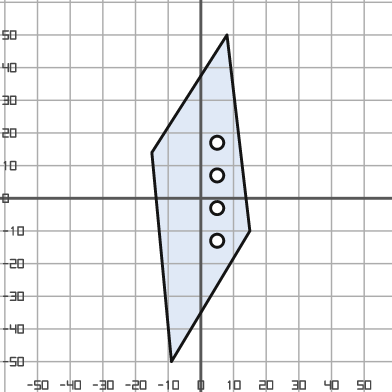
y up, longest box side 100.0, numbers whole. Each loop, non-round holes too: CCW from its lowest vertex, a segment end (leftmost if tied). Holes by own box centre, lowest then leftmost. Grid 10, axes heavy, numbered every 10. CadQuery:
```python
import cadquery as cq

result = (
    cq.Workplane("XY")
    .moveTo(-9.0, -50.0)
    .lineTo(15.0, -10.0)
    .lineTo(8.0, 50.0)
    .lineTo(-15.0, 14.0)
    .close()
    .moveTo(5.0, -13.0)
    .circle(2.0)
    .moveTo(5.0, -3.0)
    .circle(2.0)
    .moveTo(5.0, 7.0)
    .circle(2.0)
    .moveTo(5.0, 17.0)
    .circle(2.0)
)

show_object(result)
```